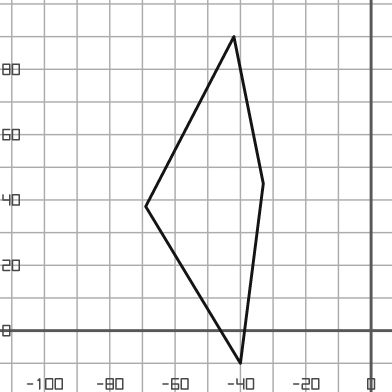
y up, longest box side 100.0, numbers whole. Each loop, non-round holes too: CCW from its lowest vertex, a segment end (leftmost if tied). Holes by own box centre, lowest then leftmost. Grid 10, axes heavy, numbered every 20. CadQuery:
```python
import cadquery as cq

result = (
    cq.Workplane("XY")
    .moveTo(-40.0, -10.0)
    .lineTo(-33.0, 45.0)
    .lineTo(-42.0, 90.0)
    .lineTo(-69.0, 38.0)
    .close()
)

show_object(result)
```